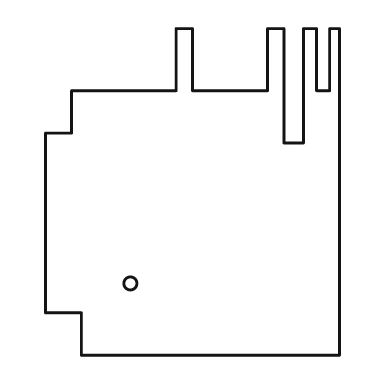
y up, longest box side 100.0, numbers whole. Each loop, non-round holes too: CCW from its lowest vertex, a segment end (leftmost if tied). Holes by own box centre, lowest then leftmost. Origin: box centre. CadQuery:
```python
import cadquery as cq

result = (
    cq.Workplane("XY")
    .moveTo(-34.0, -50.0)
    .lineTo(45.0, -50.0)
    .lineTo(45.0, 50.0)
    .lineTo(42.0, 50.0)
    .lineTo(42.0, 31.0)
    .lineTo(38.0, 31.0)
    .lineTo(38.0, 50.0)
    .lineTo(34.0, 50.0)
    .lineTo(34.0, 15.0)
    .lineTo(28.0, 15.0)
    .lineTo(28.0, 50.0)
    .lineTo(23.0, 50.0)
    .lineTo(23.0, 31.0)
    .lineTo(0.0, 31.0)
    .lineTo(0.0, 50.0)
    .lineTo(-5.0, 50.0)
    .lineTo(-5.0, 31.0)
    .lineTo(-37.0, 31.0)
    .lineTo(-37.0, 18.0)
    .lineTo(-45.0, 18.0)
    .lineTo(-45.0, -37.0)
    .lineTo(-34.0, -37.0)
    .close()
    .moveTo(-19.0, -28.0)
    .circle(2.0)
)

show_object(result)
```